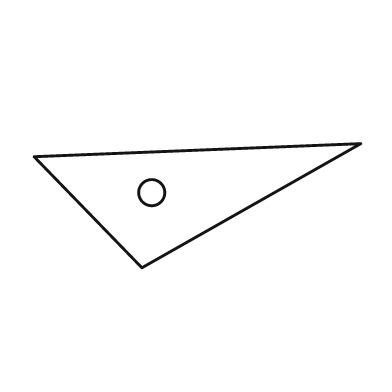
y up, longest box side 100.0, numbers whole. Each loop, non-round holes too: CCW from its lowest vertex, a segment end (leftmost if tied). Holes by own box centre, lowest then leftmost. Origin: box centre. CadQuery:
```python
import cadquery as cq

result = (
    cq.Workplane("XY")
    .moveTo(-17.0, -19.0)
    .lineTo(50.0, 19.0)
    .lineTo(-50.0, 15.0)
    .close()
    .moveTo(-14.0, 4.0)
    .circle(4.0)
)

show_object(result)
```